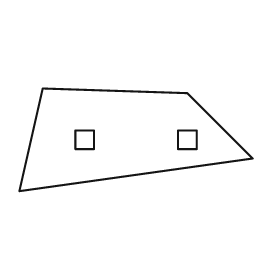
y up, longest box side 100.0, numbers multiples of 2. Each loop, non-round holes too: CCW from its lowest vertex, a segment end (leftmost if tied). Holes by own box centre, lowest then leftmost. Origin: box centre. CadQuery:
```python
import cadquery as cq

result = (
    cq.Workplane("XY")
    .moveTo(-50.0, -22.0)
    .lineTo(50.0, -8.0)
    .lineTo(22.0, 20.0)
    .lineTo(-40.0, 22.0)
    .close()
    .moveTo(-26.0, -4.0)
    .lineTo(-18.0, -4.0)
    .lineTo(-18.0, 4.0)
    .lineTo(-26.0, 4.0)
    .close()
    .moveTo(18.0, -4.0)
    .lineTo(26.0, -4.0)
    .lineTo(26.0, 4.0)
    .lineTo(18.0, 4.0)
    .close()
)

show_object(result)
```